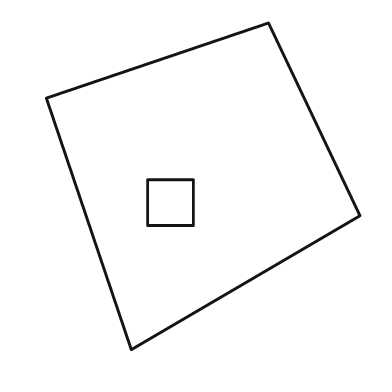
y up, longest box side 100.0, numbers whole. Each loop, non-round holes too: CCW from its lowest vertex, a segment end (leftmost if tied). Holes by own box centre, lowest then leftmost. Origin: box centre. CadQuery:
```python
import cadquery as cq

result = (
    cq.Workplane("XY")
    .moveTo(-22.0, -50.0)
    .lineTo(48.0, -9.0)
    .lineTo(20.0, 50.0)
    .lineTo(-48.0, 27.0)
    .close()
    .moveTo(-17.0, -12.0)
    .lineTo(-3.0, -12.0)
    .lineTo(-3.0, 2.0)
    .lineTo(-17.0, 2.0)
    .close()
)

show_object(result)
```